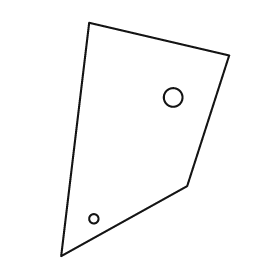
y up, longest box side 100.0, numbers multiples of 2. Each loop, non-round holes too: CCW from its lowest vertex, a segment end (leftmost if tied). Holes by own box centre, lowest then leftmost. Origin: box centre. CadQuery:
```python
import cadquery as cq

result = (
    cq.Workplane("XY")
    .moveTo(-36.0, -50.0)
    .lineTo(18.0, -20.0)
    .lineTo(36.0, 36.0)
    .lineTo(-24.0, 50.0)
    .close()
    .moveTo(-22.0, -34.0)
    .circle(2.0)
    .moveTo(12.0, 18.0)
    .circle(4.0)
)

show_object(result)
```